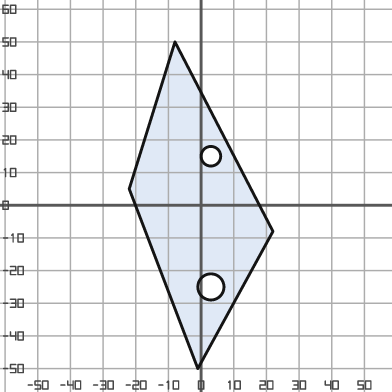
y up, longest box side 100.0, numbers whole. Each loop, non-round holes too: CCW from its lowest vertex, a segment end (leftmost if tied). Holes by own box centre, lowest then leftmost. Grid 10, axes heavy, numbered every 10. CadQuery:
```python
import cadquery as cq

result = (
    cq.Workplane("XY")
    .moveTo(-1.0, -50.0)
    .lineTo(22.0, -8.0)
    .lineTo(-8.0, 50.0)
    .lineTo(-22.0, 5.0)
    .close()
    .moveTo(3.0, -25.0)
    .circle(4.0)
    .moveTo(3.0, 15.0)
    .circle(3.0)
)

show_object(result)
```